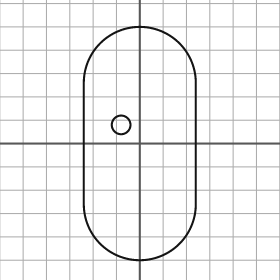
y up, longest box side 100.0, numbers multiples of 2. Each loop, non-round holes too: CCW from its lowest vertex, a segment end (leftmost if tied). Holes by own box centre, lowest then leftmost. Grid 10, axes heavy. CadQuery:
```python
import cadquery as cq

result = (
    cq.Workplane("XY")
    .moveTo(-24.0, -26.0)
    .threePointArc((0.0, -50.0), (24.0, -26.0))
    .lineTo(24.0, 26.0)
    .threePointArc((0.0, 50.0), (-24.0, 26.0))
    .close()
    .moveTo(-8.0, 8.0)
    .circle(4.0)
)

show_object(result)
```